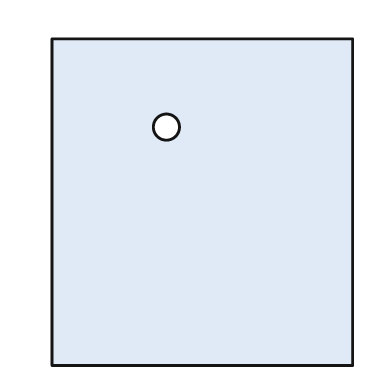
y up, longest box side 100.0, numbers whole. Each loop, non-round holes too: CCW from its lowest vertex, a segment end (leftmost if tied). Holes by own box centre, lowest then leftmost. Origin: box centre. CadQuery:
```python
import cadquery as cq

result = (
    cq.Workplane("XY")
    .moveTo(-46.0, -50.0)
    .lineTo(46.0, -50.0)
    .lineTo(46.0, 50.0)
    .lineTo(-46.0, 50.0)
    .close()
    .moveTo(-11.0, 23.0)
    .circle(4.0)
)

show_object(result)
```